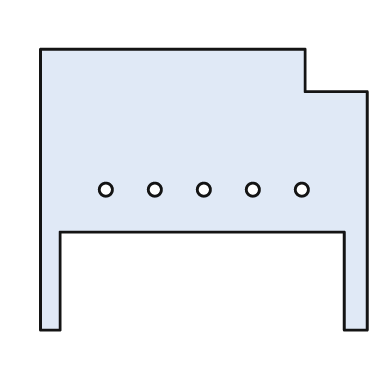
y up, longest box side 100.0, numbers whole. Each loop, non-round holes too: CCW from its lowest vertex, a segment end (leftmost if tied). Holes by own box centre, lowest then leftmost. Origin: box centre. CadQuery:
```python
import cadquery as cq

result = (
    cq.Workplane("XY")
    .moveTo(-50.0, -43.0)
    .lineTo(-44.0, -43.0)
    .lineTo(-44.0, -13.0)
    .lineTo(43.0, -13.0)
    .lineTo(43.0, -43.0)
    .lineTo(50.0, -43.0)
    .lineTo(50.0, 30.0)
    .lineTo(31.0, 30.0)
    .lineTo(31.0, 43.0)
    .lineTo(-50.0, 43.0)
    .close()
    .moveTo(-30.0, 0.0)
    .circle(2.0)
    .moveTo(-15.0, 0.0)
    .circle(2.0)
    .moveTo(0.0, 0.0)
    .circle(2.0)
    .moveTo(15.0, 0.0)
    .circle(2.0)
    .moveTo(30.0, 0.0)
    .circle(2.0)
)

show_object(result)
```